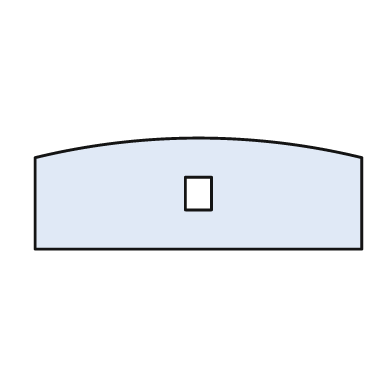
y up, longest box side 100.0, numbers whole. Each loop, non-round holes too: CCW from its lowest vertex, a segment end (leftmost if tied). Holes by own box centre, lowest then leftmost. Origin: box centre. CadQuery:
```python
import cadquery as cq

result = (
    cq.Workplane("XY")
    .moveTo(-50.0, -17.0)
    .lineTo(50.0, -17.0)
    .lineTo(50.0, 11.0)
    .threePointArc((0.0, 17.0), (-50.0, 11.0))
    .close()
    .moveTo(-4.0, -5.0)
    .lineTo(4.0, -5.0)
    .lineTo(4.0, 5.0)
    .lineTo(-4.0, 5.0)
    .close()
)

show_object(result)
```